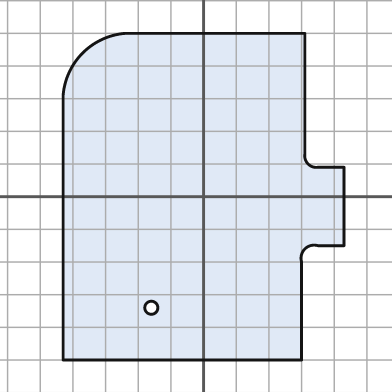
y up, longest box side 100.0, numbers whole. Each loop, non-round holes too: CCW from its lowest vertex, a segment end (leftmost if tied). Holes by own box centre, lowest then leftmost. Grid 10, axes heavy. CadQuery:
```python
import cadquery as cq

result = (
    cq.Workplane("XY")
    .moveTo(-43.0, -50.0)
    .lineTo(30.0, -50.0)
    .lineTo(30.0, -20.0)
    .threePointArc((31.0, -16.0), (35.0, -15.0))
    .lineTo(43.0, -15.0)
    .lineTo(43.0, 9.0)
    .lineTo(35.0, 9.0)
    .threePointArc((32.0, 10.0), (31.0, 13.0))
    .lineTo(31.0, 50.0)
    .lineTo(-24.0, 50.0)
    .threePointArc((-37.0, 44.0), (-43.0, 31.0))
    .close()
    .moveTo(-16.0, -34.0)
    .circle(2.0)
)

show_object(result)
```